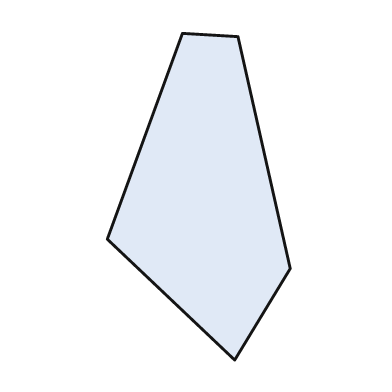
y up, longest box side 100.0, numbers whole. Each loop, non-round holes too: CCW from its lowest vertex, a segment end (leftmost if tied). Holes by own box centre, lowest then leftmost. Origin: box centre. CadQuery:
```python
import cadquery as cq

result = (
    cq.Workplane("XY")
    .moveTo(11.0, -50.0)
    .lineTo(28.0, -22.0)
    .lineTo(12.0, 49.0)
    .lineTo(-5.0, 50.0)
    .lineTo(-28.0, -13.0)
    .close()
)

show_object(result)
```